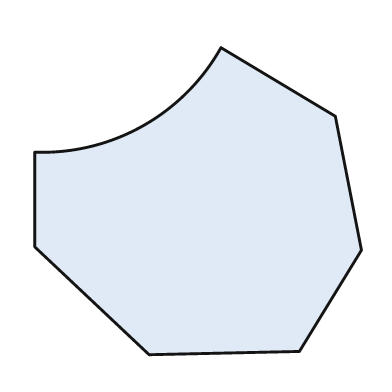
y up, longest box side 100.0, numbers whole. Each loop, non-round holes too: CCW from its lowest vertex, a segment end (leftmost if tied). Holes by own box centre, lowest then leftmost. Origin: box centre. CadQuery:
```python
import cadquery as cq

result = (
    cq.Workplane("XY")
    .moveTo(-15.0, -47.0)
    .lineTo(31.0, -46.0)
    .lineTo(50.0, -15.0)
    .lineTo(42.0, 26.0)
    .lineTo(7.0, 47.0)
    .threePointArc((-17.0, 23.0), (-50.0, 15.0))
    .lineTo(-50.0, -14.0)
    .close()
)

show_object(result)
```